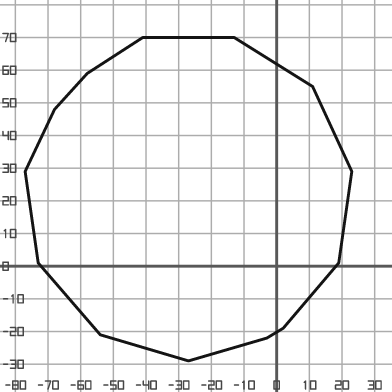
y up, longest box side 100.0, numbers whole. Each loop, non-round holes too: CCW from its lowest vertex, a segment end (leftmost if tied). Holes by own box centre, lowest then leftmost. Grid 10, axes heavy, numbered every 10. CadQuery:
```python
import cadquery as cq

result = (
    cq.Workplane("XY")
    .moveTo(-27.0, -29.0)
    .lineTo(-3.0, -22.0)
    .lineTo(2.0, -19.0)
    .lineTo(19.0, 1.0)
    .lineTo(23.0, 29.0)
    .lineTo(11.0, 55.0)
    .lineTo(-13.0, 70.0)
    .lineTo(-41.0, 70.0)
    .lineTo(-58.0, 59.0)
    .lineTo(-68.0, 48.0)
    .lineTo(-77.0, 29.0)
    .lineTo(-73.0, 1.0)
    .lineTo(-54.0, -21.0)
    .close()
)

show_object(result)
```